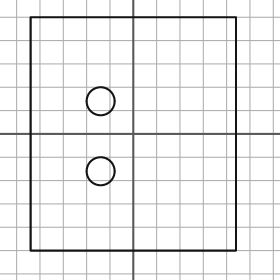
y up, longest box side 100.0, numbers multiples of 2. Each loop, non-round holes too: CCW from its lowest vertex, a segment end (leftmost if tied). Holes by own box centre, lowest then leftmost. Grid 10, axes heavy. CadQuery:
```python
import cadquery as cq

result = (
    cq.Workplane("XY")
    .moveTo(-44.0, -50.0)
    .lineTo(44.0, -50.0)
    .lineTo(44.0, 50.0)
    .lineTo(-44.0, 50.0)
    .close()
    .moveTo(-14.0, -16.0)
    .circle(6.0)
    .moveTo(-14.0, 14.0)
    .circle(6.0)
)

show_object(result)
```